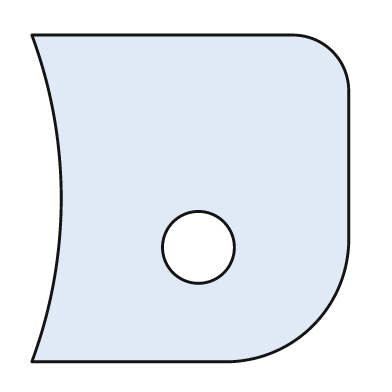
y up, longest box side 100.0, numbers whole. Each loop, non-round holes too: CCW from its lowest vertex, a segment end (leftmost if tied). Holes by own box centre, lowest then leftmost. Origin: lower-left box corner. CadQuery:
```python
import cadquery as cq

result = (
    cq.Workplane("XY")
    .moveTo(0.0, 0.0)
    .lineTo(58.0, 0.0)
    .threePointArc((86.0, 11.0), (97.0, 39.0))
    .lineTo(97.0, 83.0)
    .threePointArc((92.0, 95.0), (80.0, 100.0))
    .lineTo(0.0, 100.0)
    .threePointArc((9.0, 50.0), (0.0, 0.0))
    .close()
    .moveTo(51.0, 35.0)
    .circle(11.0)
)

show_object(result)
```